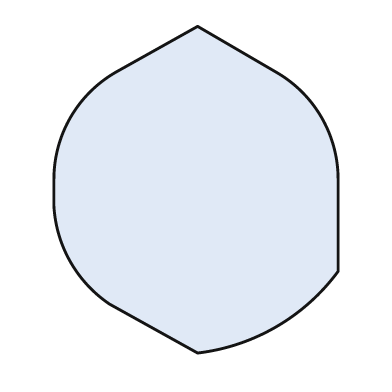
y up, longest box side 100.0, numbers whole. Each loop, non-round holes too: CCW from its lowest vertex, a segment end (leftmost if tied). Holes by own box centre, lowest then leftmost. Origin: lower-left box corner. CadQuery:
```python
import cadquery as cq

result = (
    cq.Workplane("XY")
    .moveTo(44.0, 0.0)
    .threePointArc((68.0, 8.0), (87.0, 25.0))
    .lineTo(87.0, 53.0)
    .threePointArc((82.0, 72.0), (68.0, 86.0))
    .lineTo(44.0, 100.0)
    .lineTo(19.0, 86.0)
    .threePointArc((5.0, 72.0), (0.0, 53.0))
    .lineTo(0.0, 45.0)
    .threePointArc((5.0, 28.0), (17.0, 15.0))
    .close()
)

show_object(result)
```